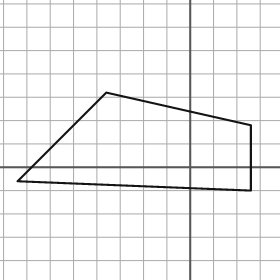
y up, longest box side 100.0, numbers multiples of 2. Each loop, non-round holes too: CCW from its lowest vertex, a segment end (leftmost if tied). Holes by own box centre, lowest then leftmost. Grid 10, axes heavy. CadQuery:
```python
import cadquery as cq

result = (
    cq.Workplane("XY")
    .moveTo(26.0, -10.0)
    .lineTo(26.0, 18.0)
    .lineTo(-36.0, 32.0)
    .lineTo(-74.0, -6.0)
    .close()
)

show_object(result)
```